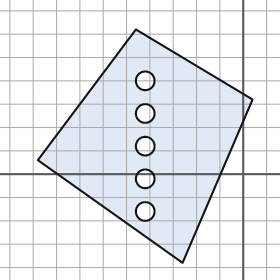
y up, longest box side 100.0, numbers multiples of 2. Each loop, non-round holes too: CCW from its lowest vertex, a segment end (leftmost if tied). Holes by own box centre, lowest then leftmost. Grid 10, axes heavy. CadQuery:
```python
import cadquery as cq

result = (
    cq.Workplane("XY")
    .moveTo(-26.0, -38.0)
    .lineTo(4.0, 32.0)
    .lineTo(-46.0, 62.0)
    .lineTo(-88.0, 6.0)
    .close()
    .moveTo(-42.0, -16.0)
    .circle(4.0)
    .moveTo(-42.0, -2.0)
    .circle(4.0)
    .moveTo(-42.0, 12.0)
    .circle(4.0)
    .moveTo(-42.0, 26.0)
    .circle(4.0)
    .moveTo(-42.0, 40.0)
    .circle(4.0)
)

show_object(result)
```